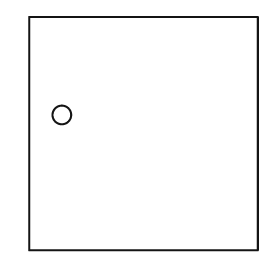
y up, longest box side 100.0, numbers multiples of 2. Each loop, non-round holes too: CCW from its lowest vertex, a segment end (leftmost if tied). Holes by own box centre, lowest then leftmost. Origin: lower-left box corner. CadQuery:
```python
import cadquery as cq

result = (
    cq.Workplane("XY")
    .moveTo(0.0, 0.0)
    .lineTo(98.0, 0.0)
    .lineTo(98.0, 100.0)
    .lineTo(0.0, 100.0)
    .close()
    .moveTo(14.0, 58.0)
    .circle(4.0)
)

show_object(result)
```